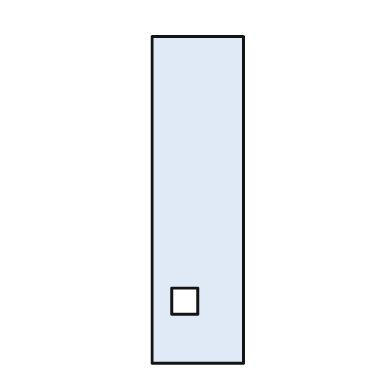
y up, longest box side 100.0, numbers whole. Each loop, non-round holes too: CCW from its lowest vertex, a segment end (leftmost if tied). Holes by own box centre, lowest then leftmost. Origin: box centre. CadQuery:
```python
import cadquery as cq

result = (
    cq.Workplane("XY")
    .moveTo(-14.0, -50.0)
    .lineTo(14.0, -50.0)
    .lineTo(14.0, 50.0)
    .lineTo(-14.0, 50.0)
    .close()
    .moveTo(-8.0, -35.0)
    .lineTo(0.0, -35.0)
    .lineTo(0.0, -27.0)
    .lineTo(-8.0, -27.0)
    .close()
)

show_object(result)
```